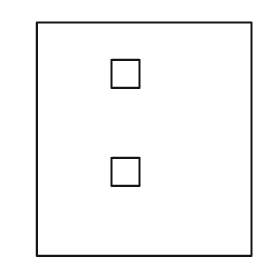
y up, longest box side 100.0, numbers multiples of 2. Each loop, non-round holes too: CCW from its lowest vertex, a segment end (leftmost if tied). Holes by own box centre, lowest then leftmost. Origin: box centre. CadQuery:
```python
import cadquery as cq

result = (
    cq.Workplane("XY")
    .moveTo(-46.0, -50.0)
    .lineTo(46.0, -50.0)
    .lineTo(46.0, 50.0)
    .lineTo(-46.0, 50.0)
    .close()
    .moveTo(-14.0, -20.0)
    .lineTo(-2.0, -20.0)
    .lineTo(-2.0, -8.0)
    .lineTo(-14.0, -8.0)
    .close()
    .moveTo(-14.0, 22.0)
    .lineTo(-2.0, 22.0)
    .lineTo(-2.0, 34.0)
    .lineTo(-14.0, 34.0)
    .close()
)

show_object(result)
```